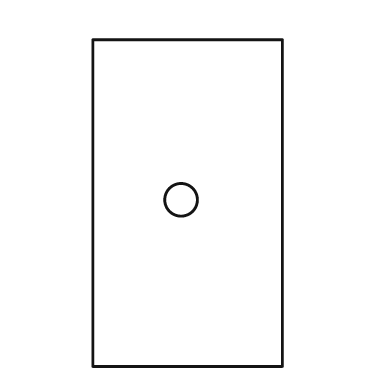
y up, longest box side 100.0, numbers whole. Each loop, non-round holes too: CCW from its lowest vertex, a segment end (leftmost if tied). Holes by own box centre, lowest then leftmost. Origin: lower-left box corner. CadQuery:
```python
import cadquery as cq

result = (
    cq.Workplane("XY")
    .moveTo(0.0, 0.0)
    .lineTo(58.0, 0.0)
    .lineTo(58.0, 100.0)
    .lineTo(0.0, 100.0)
    .close()
    .moveTo(27.0, 51.0)
    .circle(5.0)
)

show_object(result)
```